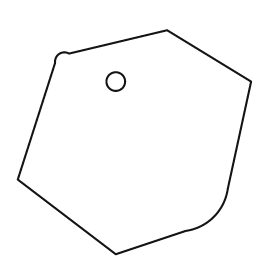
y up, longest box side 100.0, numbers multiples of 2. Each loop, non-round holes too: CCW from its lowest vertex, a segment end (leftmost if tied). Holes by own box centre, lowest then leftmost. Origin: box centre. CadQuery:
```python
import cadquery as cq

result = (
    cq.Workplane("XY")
    .moveTo(-8.0, -48.0)
    .lineTo(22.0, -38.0)
    .threePointArc((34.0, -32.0), (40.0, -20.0))
    .lineTo(50.0, 26.0)
    .lineTo(14.0, 48.0)
    .lineTo(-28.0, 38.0)
    .threePointArc((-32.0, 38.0), (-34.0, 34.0))
    .lineTo(-50.0, -16.0)
    .close()
    .moveTo(-8.0, 26.0)
    .circle(4.0)
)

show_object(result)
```